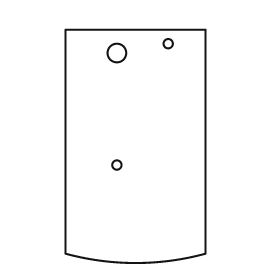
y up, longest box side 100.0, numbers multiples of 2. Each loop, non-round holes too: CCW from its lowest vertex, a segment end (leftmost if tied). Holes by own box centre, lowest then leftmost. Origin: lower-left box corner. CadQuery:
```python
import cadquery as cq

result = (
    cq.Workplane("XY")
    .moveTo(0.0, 4.0)
    .threePointArc((30.0, 0.0), (60.0, 4.0))
    .lineTo(60.0, 100.0)
    .lineTo(0.0, 100.0)
    .close()
    .moveTo(22.0, 42.0)
    .circle(2.0)
    .moveTo(22.0, 90.0)
    .circle(4.0)
    .moveTo(44.0, 94.0)
    .circle(2.0)
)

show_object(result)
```